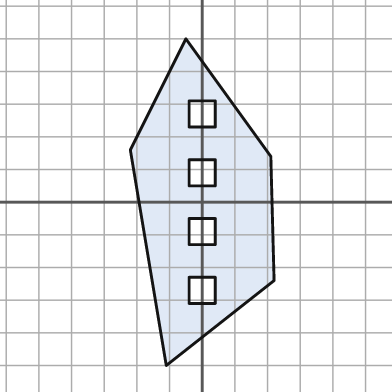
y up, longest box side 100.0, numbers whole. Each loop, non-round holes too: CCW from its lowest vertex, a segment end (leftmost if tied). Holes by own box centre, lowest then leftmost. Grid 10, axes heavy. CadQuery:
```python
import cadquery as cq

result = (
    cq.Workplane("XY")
    .moveTo(-11.0, -50.0)
    .lineTo(22.0, -24.0)
    .lineTo(21.0, 14.0)
    .lineTo(-5.0, 50.0)
    .lineTo(-22.0, 16.0)
    .close()
    .moveTo(-4.0, -31.0)
    .lineTo(4.0, -31.0)
    .lineTo(4.0, -23.0)
    .lineTo(-4.0, -23.0)
    .close()
    .moveTo(-4.0, -13.0)
    .lineTo(4.0, -13.0)
    .lineTo(4.0, -5.0)
    .lineTo(-4.0, -5.0)
    .close()
    .moveTo(-4.0, 5.0)
    .lineTo(4.0, 5.0)
    .lineTo(4.0, 13.0)
    .lineTo(-4.0, 13.0)
    .close()
    .moveTo(-4.0, 23.0)
    .lineTo(4.0, 23.0)
    .lineTo(4.0, 31.0)
    .lineTo(-4.0, 31.0)
    .close()
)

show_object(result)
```